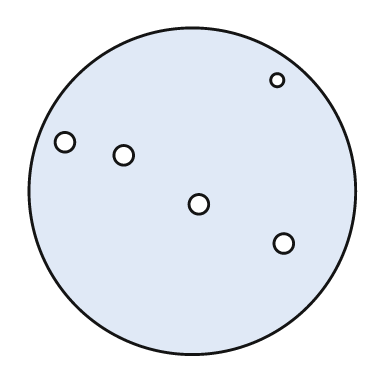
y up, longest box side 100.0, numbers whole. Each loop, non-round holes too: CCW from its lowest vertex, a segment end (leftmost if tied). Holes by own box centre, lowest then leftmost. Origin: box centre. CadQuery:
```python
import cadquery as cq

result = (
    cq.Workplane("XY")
    .moveTo(0.0, 0.0)
    .circle(50.0)
    .moveTo(28.0, -16.0)
    .circle(3.0)
    .moveTo(2.0, -4.0)
    .circle(3.0)
    .moveTo(-21.0, 11.0)
    .circle(3.0)
    .moveTo(-39.0, 15.0)
    .circle(3.0)
    .moveTo(26.0, 34.0)
    .circle(2.0)
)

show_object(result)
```